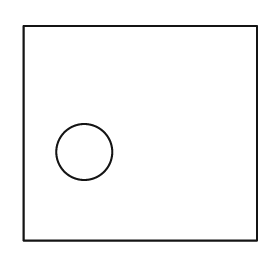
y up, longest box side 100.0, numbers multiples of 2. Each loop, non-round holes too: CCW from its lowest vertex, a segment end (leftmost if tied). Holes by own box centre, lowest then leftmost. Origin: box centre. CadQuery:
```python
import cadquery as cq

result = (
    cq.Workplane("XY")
    .moveTo(-50.0, -46.0)
    .lineTo(50.0, -46.0)
    .lineTo(50.0, 46.0)
    .lineTo(-50.0, 46.0)
    .close()
    .moveTo(-24.0, -8.0)
    .circle(12.0)
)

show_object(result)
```